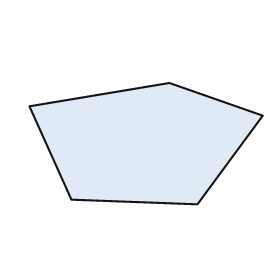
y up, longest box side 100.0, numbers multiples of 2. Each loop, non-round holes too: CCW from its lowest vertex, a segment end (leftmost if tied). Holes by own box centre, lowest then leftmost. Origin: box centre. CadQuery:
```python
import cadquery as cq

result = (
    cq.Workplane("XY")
    .moveTo(22.0, -26.0)
    .lineTo(50.0, 12.0)
    .lineTo(10.0, 26.0)
    .lineTo(-50.0, 16.0)
    .lineTo(-32.0, -24.0)
    .close()
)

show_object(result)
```